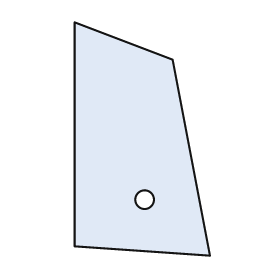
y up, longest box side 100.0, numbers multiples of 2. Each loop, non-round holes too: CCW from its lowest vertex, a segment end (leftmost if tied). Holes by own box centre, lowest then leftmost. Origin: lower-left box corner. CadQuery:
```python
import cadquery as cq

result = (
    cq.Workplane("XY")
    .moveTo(58.0, 0.0)
    .lineTo(42.0, 84.0)
    .lineTo(0.0, 100.0)
    .lineTo(0.0, 4.0)
    .close()
    .moveTo(30.0, 24.0)
    .circle(4.0)
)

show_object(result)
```